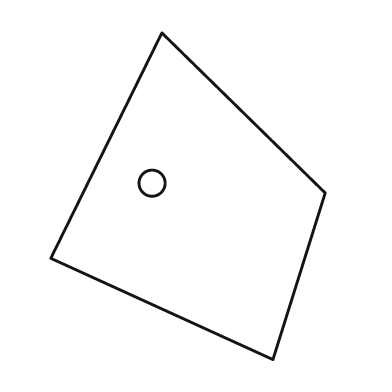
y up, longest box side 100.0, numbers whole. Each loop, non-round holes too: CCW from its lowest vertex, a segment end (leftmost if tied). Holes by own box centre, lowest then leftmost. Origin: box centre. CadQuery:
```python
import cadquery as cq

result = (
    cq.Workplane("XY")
    .moveTo(26.0, -50.0)
    .lineTo(42.0, 1.0)
    .lineTo(-8.0, 50.0)
    .lineTo(-42.0, -19.0)
    .close()
    .moveTo(-11.0, 4.0)
    .circle(4.0)
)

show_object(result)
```